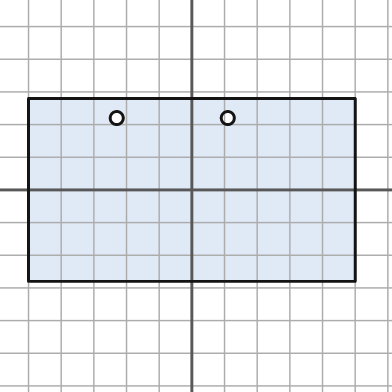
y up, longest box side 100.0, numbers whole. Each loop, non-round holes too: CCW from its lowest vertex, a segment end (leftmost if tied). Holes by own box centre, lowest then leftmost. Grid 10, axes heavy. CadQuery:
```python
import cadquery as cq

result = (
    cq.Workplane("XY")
    .moveTo(-50.0, -28.0)
    .lineTo(50.0, -28.0)
    .lineTo(50.0, 28.0)
    .lineTo(-50.0, 28.0)
    .close()
    .moveTo(-23.0, 22.0)
    .circle(2.0)
    .moveTo(11.0, 22.0)
    .circle(2.0)
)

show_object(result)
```